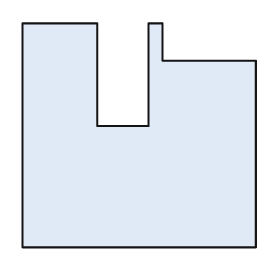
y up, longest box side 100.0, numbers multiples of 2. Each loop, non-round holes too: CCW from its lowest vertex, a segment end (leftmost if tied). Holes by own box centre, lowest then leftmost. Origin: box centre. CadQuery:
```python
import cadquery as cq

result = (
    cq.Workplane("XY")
    .moveTo(-50.0, -48.0)
    .lineTo(50.0, -48.0)
    .lineTo(50.0, 32.0)
    .lineTo(10.0, 32.0)
    .lineTo(10.0, 48.0)
    .lineTo(4.0, 48.0)
    .lineTo(4.0, 4.0)
    .lineTo(-18.0, 4.0)
    .lineTo(-18.0, 48.0)
    .lineTo(-50.0, 48.0)
    .close()
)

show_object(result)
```